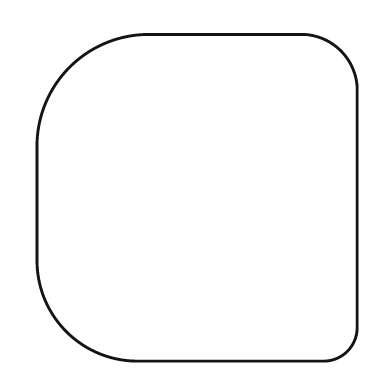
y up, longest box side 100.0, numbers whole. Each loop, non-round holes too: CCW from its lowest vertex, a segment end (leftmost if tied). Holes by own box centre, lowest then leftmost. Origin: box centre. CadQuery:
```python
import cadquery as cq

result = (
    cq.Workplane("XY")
    .moveTo(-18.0, -50.0)
    .lineTo(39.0, -50.0)
    .threePointArc((46.0, -47.0), (49.0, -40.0))
    .lineTo(49.0, 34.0)
    .threePointArc((44.0, 45.0), (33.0, 50.0))
    .lineTo(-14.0, 50.0)
    .threePointArc((-39.0, 40.0), (-49.0, 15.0))
    .lineTo(-49.0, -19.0)
    .threePointArc((-40.0, -41.0), (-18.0, -50.0))
    .close()
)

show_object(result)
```